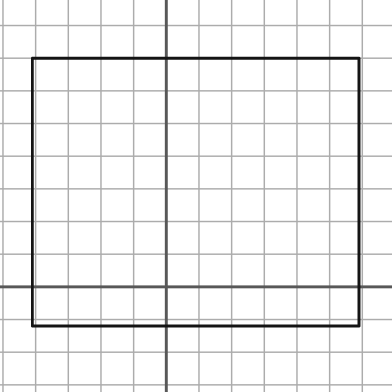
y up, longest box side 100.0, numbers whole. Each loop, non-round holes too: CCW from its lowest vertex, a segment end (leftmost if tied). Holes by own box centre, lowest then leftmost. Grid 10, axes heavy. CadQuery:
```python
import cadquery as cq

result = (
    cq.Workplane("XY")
    .moveTo(-41.0, -12.0)
    .lineTo(59.0, -12.0)
    .lineTo(59.0, 70.0)
    .lineTo(-41.0, 70.0)
    .close()
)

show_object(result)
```